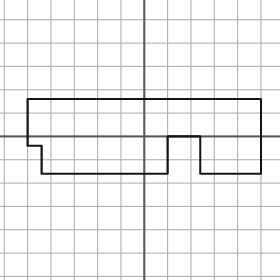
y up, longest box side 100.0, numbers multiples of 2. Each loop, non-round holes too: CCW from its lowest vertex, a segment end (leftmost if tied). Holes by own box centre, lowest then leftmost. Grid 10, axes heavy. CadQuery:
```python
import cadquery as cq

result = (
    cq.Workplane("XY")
    .moveTo(-44.0, -16.0)
    .lineTo(10.0, -16.0)
    .lineTo(10.0, 0.0)
    .lineTo(24.0, 0.0)
    .lineTo(24.0, -16.0)
    .lineTo(50.0, -16.0)
    .lineTo(50.0, 16.0)
    .lineTo(-50.0, 16.0)
    .lineTo(-50.0, -4.0)
    .lineTo(-44.0, -4.0)
    .close()
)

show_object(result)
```